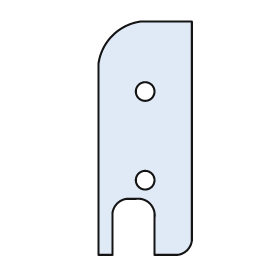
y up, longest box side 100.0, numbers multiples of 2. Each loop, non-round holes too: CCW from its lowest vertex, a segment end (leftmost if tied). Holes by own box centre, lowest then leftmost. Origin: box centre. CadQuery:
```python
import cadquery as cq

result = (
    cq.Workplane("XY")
    .moveTo(-20.0, -50.0)
    .lineTo(-14.0, -50.0)
    .lineTo(-14.0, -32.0)
    .threePointArc((-12.0, -28.0), (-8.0, -26.0))
    .lineTo(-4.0, -26.0)
    .threePointArc((2.0, -28.0), (4.0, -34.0))
    .lineTo(4.0, -50.0)
    .lineTo(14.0, -50.0)
    .threePointArc((18.0, -48.0), (20.0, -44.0))
    .lineTo(20.0, 50.0)
    .lineTo(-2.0, 50.0)
    .threePointArc((-14.0, 44.0), (-20.0, 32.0))
    .close()
    .moveTo(0.0, -18.0)
    .circle(4.0)
    .moveTo(0.0, 20.0)
    .circle(4.0)
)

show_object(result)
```